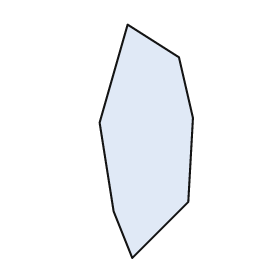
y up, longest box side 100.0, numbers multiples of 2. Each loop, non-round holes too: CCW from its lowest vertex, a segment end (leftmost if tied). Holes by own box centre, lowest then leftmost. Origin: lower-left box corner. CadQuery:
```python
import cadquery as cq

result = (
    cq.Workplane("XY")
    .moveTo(14.0, 0.0)
    .lineTo(38.0, 24.0)
    .lineTo(40.0, 60.0)
    .lineTo(34.0, 86.0)
    .lineTo(12.0, 100.0)
    .lineTo(0.0, 58.0)
    .lineTo(6.0, 20.0)
    .close()
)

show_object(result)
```